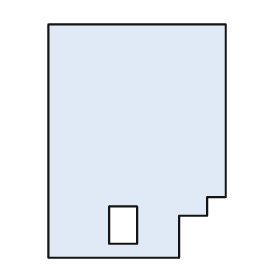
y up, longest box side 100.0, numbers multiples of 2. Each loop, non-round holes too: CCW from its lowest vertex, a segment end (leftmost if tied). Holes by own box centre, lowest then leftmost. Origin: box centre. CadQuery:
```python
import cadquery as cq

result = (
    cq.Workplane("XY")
    .moveTo(-38.0, -50.0)
    .lineTo(18.0, -50.0)
    .lineTo(18.0, -32.0)
    .lineTo(30.0, -32.0)
    .lineTo(30.0, -24.0)
    .lineTo(38.0, -24.0)
    .lineTo(38.0, 50.0)
    .lineTo(-38.0, 50.0)
    .close()
    .moveTo(-12.0, -44.0)
    .lineTo(0.0, -44.0)
    .lineTo(0.0, -28.0)
    .lineTo(-12.0, -28.0)
    .close()
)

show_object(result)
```